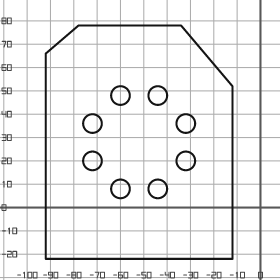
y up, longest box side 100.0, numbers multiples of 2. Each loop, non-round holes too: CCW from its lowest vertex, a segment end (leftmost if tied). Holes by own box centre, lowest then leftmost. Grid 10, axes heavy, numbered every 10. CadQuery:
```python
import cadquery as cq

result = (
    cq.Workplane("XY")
    .moveTo(-92.0, -22.0)
    .lineTo(-12.0, -22.0)
    .lineTo(-12.0, 52.0)
    .lineTo(-34.0, 78.0)
    .lineTo(-78.0, 78.0)
    .lineTo(-92.0, 66.0)
    .close()
    .moveTo(-60.0, 8.0)
    .circle(4.0)
    .moveTo(-44.0, 8.0)
    .circle(4.0)
    .moveTo(-72.0, 20.0)
    .circle(4.0)
    .moveTo(-32.0, 20.0)
    .circle(4.0)
    .moveTo(-72.0, 36.0)
    .circle(4.0)
    .moveTo(-32.0, 36.0)
    .circle(4.0)
    .moveTo(-60.0, 48.0)
    .circle(4.0)
    .moveTo(-44.0, 48.0)
    .circle(4.0)
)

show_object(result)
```